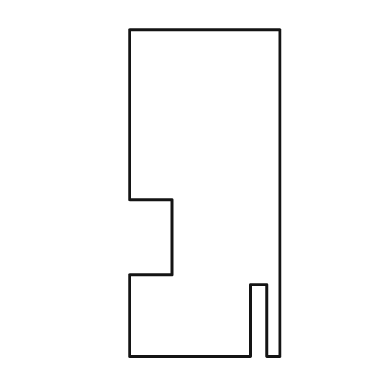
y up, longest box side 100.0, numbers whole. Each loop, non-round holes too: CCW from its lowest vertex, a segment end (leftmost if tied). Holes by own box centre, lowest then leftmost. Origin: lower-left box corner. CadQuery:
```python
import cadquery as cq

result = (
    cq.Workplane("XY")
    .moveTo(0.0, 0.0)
    .lineTo(37.0, 0.0)
    .lineTo(37.0, 22.0)
    .lineTo(42.0, 22.0)
    .lineTo(42.0, 0.0)
    .lineTo(46.0, 0.0)
    .lineTo(46.0, 100.0)
    .lineTo(0.0, 100.0)
    .lineTo(0.0, 48.0)
    .lineTo(13.0, 48.0)
    .lineTo(13.0, 25.0)
    .lineTo(0.0, 25.0)
    .close()
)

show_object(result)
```